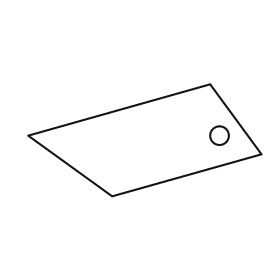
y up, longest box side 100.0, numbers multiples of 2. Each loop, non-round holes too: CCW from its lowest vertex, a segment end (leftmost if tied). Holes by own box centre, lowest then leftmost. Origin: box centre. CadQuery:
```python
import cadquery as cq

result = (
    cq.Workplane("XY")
    .moveTo(-14.0, -24.0)
    .lineTo(50.0, -6.0)
    .lineTo(28.0, 24.0)
    .lineTo(-50.0, 2.0)
    .close()
    .moveTo(32.0, 2.0)
    .circle(4.0)
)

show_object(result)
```